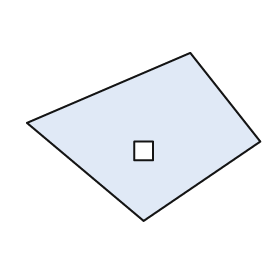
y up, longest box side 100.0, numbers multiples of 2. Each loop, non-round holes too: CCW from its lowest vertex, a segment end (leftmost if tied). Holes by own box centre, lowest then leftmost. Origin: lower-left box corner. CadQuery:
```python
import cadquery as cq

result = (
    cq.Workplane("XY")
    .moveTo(50.0, 0.0)
    .lineTo(100.0, 34.0)
    .lineTo(70.0, 72.0)
    .lineTo(0.0, 42.0)
    .close()
    .moveTo(46.0, 26.0)
    .lineTo(54.0, 26.0)
    .lineTo(54.0, 34.0)
    .lineTo(46.0, 34.0)
    .close()
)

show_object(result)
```